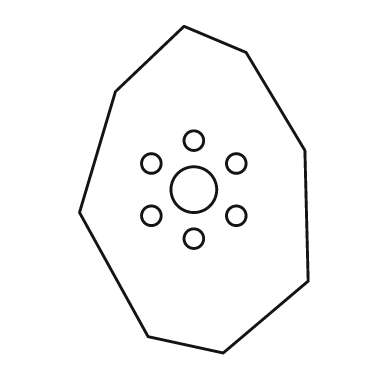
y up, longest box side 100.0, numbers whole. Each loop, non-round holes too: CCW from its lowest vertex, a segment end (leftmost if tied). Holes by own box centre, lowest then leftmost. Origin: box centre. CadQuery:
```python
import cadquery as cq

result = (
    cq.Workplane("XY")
    .moveTo(9.0, -50.0)
    .lineTo(35.0, -28.0)
    .lineTo(34.0, 12.0)
    .lineTo(16.0, 42.0)
    .lineTo(-3.0, 50.0)
    .lineTo(-24.0, 30.0)
    .lineTo(-35.0, -7.0)
    .lineTo(-14.0, -45.0)
    .close()
    .moveTo(0.0, -15.0)
    .circle(3.0)
    .moveTo(-13.0, -8.0)
    .circle(3.0)
    .moveTo(13.0, -8.0)
    .circle(3.0)
    .moveTo(0.0, 0.0)
    .circle(7.0)
    .moveTo(-13.0, 8.0)
    .circle(3.0)
    .moveTo(13.0, 8.0)
    .circle(3.0)
    .moveTo(0.0, 15.0)
    .circle(3.0)
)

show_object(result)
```